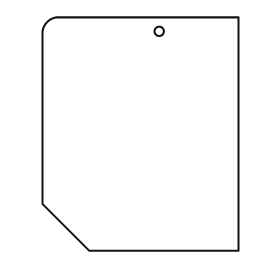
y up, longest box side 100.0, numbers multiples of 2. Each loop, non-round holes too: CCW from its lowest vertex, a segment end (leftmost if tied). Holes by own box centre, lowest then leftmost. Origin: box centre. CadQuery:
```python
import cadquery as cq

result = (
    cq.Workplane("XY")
    .moveTo(-22.0, -50.0)
    .lineTo(42.0, -50.0)
    .lineTo(42.0, 50.0)
    .lineTo(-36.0, 50.0)
    .threePointArc((-40.0, 48.0), (-42.0, 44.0))
    .lineTo(-42.0, -30.0)
    .close()
    .moveTo(8.0, 44.0)
    .circle(2.0)
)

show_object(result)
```